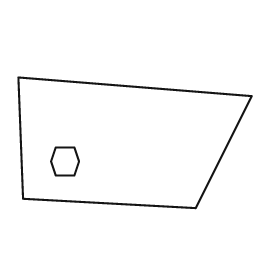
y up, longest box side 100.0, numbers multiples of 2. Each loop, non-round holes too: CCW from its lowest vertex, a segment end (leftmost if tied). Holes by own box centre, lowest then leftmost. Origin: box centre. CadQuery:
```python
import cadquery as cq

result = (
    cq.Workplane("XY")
    .moveTo(26.0, -28.0)
    .lineTo(50.0, 20.0)
    .lineTo(-50.0, 28.0)
    .lineTo(-48.0, -24.0)
    .close()
    .moveTo(-34.0, -14.0)
    .lineTo(-26.0, -14.0)
    .lineTo(-24.0, -8.0)
    .lineTo(-26.0, -2.0)
    .lineTo(-34.0, -2.0)
    .lineTo(-36.0, -8.0)
    .close()
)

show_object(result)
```